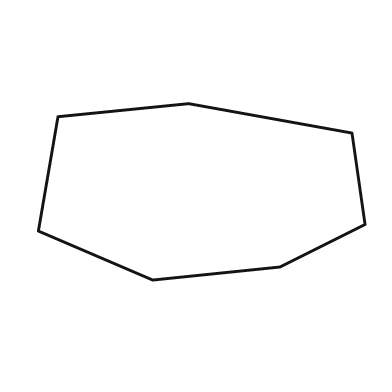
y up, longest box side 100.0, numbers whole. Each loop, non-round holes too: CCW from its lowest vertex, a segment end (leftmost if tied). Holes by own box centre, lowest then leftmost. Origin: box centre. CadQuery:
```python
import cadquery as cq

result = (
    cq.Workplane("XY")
    .moveTo(-15.0, -27.0)
    .lineTo(24.0, -23.0)
    .lineTo(50.0, -10.0)
    .lineTo(46.0, 18.0)
    .lineTo(-4.0, 27.0)
    .lineTo(-44.0, 23.0)
    .lineTo(-50.0, -12.0)
    .close()
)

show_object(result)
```